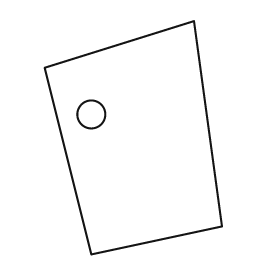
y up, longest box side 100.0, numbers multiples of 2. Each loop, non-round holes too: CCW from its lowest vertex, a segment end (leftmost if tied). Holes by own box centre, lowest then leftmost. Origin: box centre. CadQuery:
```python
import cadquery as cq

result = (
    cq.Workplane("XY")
    .moveTo(-18.0, -50.0)
    .lineTo(38.0, -38.0)
    .lineTo(26.0, 50.0)
    .lineTo(-38.0, 30.0)
    .close()
    .moveTo(-18.0, 10.0)
    .circle(6.0)
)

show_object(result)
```